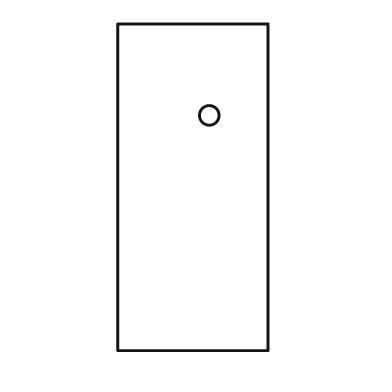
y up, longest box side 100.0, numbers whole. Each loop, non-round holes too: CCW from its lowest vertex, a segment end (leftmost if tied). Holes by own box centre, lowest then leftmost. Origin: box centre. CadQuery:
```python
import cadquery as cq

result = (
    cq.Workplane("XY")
    .moveTo(-23.0, -50.0)
    .lineTo(23.0, -50.0)
    .lineTo(23.0, 50.0)
    .lineTo(-23.0, 50.0)
    .close()
    .moveTo(5.0, 22.0)
    .circle(3.0)
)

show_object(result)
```